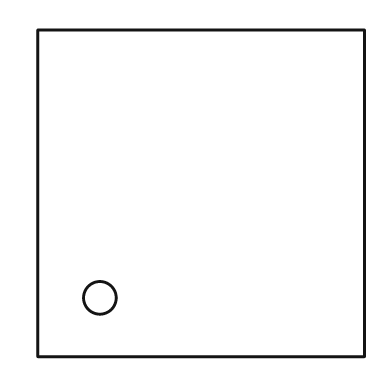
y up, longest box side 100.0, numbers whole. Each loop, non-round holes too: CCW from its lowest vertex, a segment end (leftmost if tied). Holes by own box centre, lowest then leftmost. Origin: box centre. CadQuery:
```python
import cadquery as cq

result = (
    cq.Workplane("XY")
    .moveTo(-50.0, -50.0)
    .lineTo(50.0, -50.0)
    .lineTo(50.0, 50.0)
    .lineTo(-50.0, 50.0)
    .close()
    .moveTo(-31.0, -32.0)
    .circle(5.0)
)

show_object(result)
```